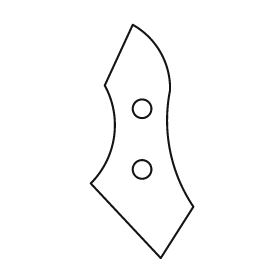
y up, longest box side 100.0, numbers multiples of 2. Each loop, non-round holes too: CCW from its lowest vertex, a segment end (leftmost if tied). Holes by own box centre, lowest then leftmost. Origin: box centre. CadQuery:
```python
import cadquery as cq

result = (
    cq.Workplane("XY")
    .moveTo(8.0, -50.0)
    .lineTo(22.0, -28.0)
    .threePointArc((12.0, -4.0), (12.0, 22.0))
    .threePointArc((8.0, 38.0), (-4.0, 50.0))
    .lineTo(-16.0, 24.0)
    .threePointArc((-12.0, 2.0), (-22.0, -18.0))
    .close()
    .moveTo(0.0, -12.0)
    .circle(4.0)
    .moveTo(0.0, 14.0)
    .circle(4.0)
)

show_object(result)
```